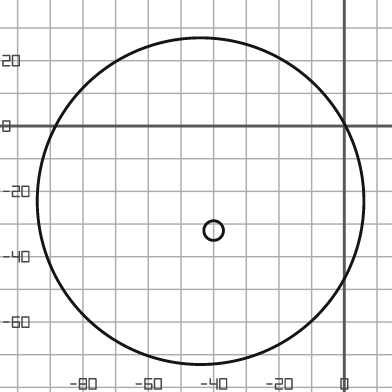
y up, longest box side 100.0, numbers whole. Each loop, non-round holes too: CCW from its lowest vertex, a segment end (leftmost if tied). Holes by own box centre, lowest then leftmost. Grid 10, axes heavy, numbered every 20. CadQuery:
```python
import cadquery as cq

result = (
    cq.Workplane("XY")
    .moveTo(-44.0, -23.0)
    .circle(50.0)
    .moveTo(-40.0, -32.0)
    .circle(3.0)
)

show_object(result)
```